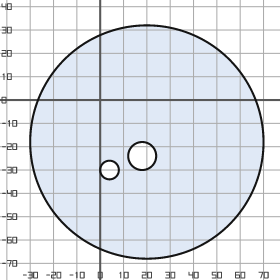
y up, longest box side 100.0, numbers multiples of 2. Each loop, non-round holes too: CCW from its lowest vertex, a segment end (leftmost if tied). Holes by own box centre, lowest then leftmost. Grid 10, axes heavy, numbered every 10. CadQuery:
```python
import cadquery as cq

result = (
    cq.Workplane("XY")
    .moveTo(20.0, -18.0)
    .circle(50.0)
    .moveTo(4.0, -30.0)
    .circle(4.0)
    .moveTo(18.0, -24.0)
    .circle(6.0)
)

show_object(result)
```